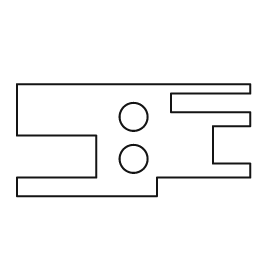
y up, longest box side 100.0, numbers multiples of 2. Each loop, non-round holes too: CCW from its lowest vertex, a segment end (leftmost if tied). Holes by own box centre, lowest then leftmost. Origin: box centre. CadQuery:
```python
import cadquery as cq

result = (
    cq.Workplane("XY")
    .moveTo(-50.0, -24.0)
    .lineTo(10.0, -24.0)
    .lineTo(10.0, -16.0)
    .lineTo(50.0, -16.0)
    .lineTo(50.0, -10.0)
    .lineTo(34.0, -10.0)
    .lineTo(34.0, 6.0)
    .lineTo(50.0, 6.0)
    .lineTo(50.0, 12.0)
    .lineTo(16.0, 12.0)
    .lineTo(16.0, 20.0)
    .lineTo(50.0, 20.0)
    .lineTo(50.0, 24.0)
    .lineTo(-50.0, 24.0)
    .lineTo(-50.0, 2.0)
    .lineTo(-16.0, 2.0)
    .lineTo(-16.0, -16.0)
    .lineTo(-50.0, -16.0)
    .close()
    .moveTo(0.0, -8.0)
    .circle(6.0)
    .moveTo(0.0, 10.0)
    .circle(6.0)
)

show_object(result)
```